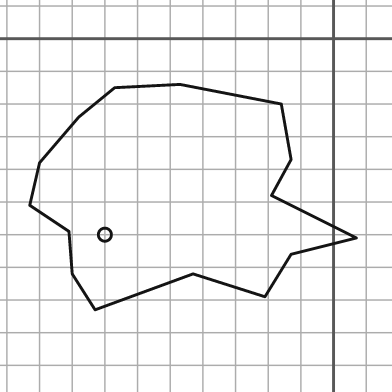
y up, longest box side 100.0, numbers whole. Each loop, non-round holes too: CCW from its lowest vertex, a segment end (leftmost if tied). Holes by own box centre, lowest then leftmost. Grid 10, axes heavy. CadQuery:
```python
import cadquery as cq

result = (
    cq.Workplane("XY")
    .moveTo(-73.0, -83.0)
    .lineTo(-43.0, -72.0)
    .lineTo(-21.0, -79.0)
    .lineTo(-13.0, -66.0)
    .lineTo(7.0, -61.0)
    .lineTo(-19.0, -48.0)
    .lineTo(-13.0, -37.0)
    .lineTo(-16.0, -20.0)
    .lineTo(-47.0, -14.0)
    .lineTo(-67.0, -15.0)
    .lineTo(-78.0, -24.0)
    .lineTo(-90.0, -38.0)
    .lineTo(-93.0, -51.0)
    .lineTo(-81.0, -59.0)
    .lineTo(-80.0, -72.0)
    .close()
    .moveTo(-70.0, -60.0)
    .circle(2.0)
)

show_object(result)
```